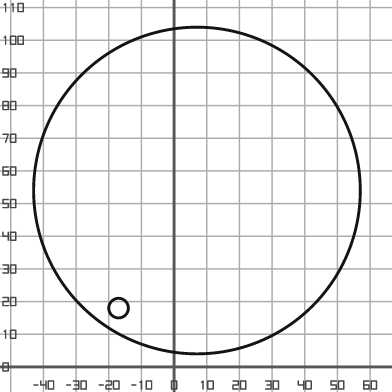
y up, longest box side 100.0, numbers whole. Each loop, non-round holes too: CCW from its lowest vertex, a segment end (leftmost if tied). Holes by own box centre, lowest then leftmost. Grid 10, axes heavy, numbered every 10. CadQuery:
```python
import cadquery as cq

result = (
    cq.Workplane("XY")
    .moveTo(7.0, 54.0)
    .circle(50.0)
    .moveTo(-17.0, 18.0)
    .circle(3.0)
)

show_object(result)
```